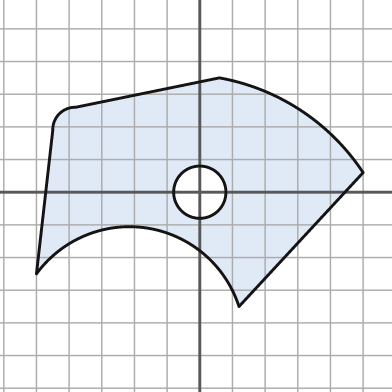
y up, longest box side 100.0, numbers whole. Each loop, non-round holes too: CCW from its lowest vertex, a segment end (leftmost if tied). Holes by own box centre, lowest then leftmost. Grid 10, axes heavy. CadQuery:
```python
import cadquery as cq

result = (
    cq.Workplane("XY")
    .moveTo(12.0, -35.0)
    .lineTo(50.0, 6.0)
    .threePointArc((31.0, 25.0), (6.0, 35.0))
    .lineTo(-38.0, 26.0)
    .threePointArc((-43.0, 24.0), (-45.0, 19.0))
    .lineTo(-50.0, -25.0)
    .threePointArc((-16.0, -11.0), (12.0, -35.0))
    .close()
    .moveTo(0.0, 0.0)
    .circle(8.0)
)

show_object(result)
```